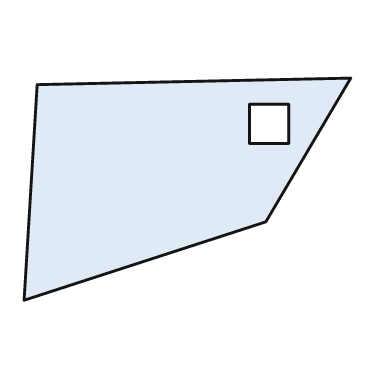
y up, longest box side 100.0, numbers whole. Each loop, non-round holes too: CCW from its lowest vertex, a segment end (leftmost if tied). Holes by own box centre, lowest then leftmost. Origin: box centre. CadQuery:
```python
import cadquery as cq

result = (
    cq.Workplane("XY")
    .moveTo(-50.0, -34.0)
    .lineTo(24.0, -10.0)
    .lineTo(50.0, 34.0)
    .lineTo(-46.0, 32.0)
    .close()
    .moveTo(19.0, 14.0)
    .lineTo(31.0, 14.0)
    .lineTo(31.0, 26.0)
    .lineTo(19.0, 26.0)
    .close()
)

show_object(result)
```